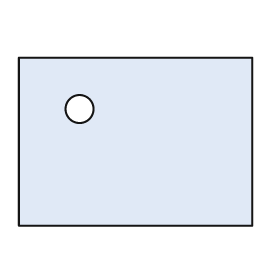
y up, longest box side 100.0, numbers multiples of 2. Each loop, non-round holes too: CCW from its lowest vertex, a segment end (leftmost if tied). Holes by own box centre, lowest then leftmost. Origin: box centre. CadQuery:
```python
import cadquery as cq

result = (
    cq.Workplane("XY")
    .moveTo(-50.0, -36.0)
    .lineTo(50.0, -36.0)
    .lineTo(50.0, 36.0)
    .lineTo(-50.0, 36.0)
    .close()
    .moveTo(-24.0, 14.0)
    .circle(6.0)
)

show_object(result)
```